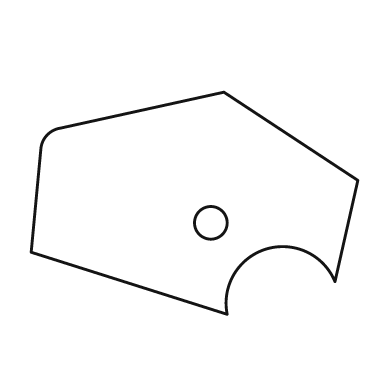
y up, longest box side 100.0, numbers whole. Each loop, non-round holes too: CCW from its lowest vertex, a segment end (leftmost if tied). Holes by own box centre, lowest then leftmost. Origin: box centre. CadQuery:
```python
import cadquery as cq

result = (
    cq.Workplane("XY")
    .moveTo(10.0, -34.0)
    .threePointArc((22.0, -14.0), (43.0, -24.0))
    .lineTo(50.0, 7.0)
    .lineTo(9.0, 34.0)
    .lineTo(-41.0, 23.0)
    .threePointArc((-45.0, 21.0), (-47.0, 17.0))
    .lineTo(-50.0, -15.0)
    .close()
    .moveTo(5.0, -6.0)
    .circle(5.0)
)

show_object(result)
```